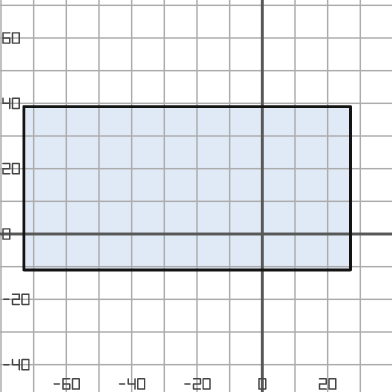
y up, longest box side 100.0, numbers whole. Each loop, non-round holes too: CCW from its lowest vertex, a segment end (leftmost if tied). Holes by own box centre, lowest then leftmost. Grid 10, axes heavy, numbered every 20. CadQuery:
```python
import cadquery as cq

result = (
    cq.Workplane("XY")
    .moveTo(-73.0, -11.0)
    .lineTo(27.0, -11.0)
    .lineTo(27.0, 39.0)
    .lineTo(-73.0, 39.0)
    .close()
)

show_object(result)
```